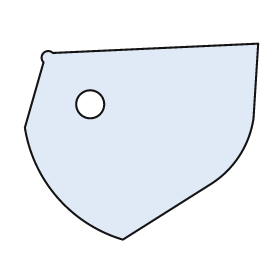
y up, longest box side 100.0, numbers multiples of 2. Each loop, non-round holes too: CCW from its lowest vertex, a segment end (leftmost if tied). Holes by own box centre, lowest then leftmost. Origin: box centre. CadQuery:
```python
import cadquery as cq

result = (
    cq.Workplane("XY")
    .moveTo(-8.0, -42.0)
    .lineTo(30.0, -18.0)
    .threePointArc((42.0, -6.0), (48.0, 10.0))
    .lineTo(50.0, 42.0)
    .lineTo(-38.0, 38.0)
    .threePointArc((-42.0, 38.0), (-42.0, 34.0))
    .lineTo(-50.0, 6.0)
    .threePointArc((-36.0, -24.0), (-8.0, -42.0))
    .close()
    .moveTo(-22.0, 16.0)
    .circle(6.0)
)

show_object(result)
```